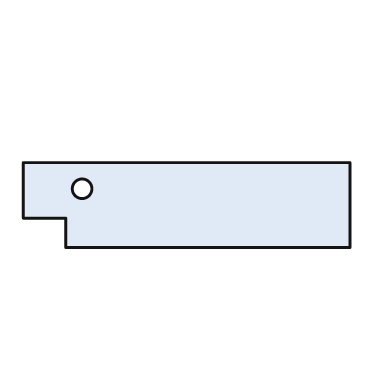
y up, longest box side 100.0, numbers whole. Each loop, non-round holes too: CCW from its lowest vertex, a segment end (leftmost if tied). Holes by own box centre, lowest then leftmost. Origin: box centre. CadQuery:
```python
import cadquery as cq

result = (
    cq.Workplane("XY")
    .moveTo(-37.0, -13.0)
    .lineTo(50.0, -13.0)
    .lineTo(50.0, 13.0)
    .lineTo(-50.0, 13.0)
    .lineTo(-50.0, -4.0)
    .lineTo(-37.0, -4.0)
    .close()
    .moveTo(-32.0, 5.0)
    .circle(3.0)
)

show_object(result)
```